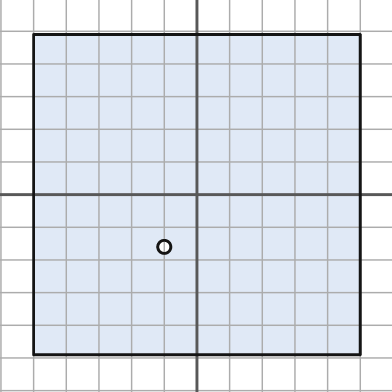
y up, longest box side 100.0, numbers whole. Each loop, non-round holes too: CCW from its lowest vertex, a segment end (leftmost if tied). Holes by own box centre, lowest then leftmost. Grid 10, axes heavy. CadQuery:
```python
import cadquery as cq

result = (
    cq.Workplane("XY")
    .moveTo(-50.0, -49.0)
    .lineTo(50.0, -49.0)
    .lineTo(50.0, 49.0)
    .lineTo(-50.0, 49.0)
    .close()
    .moveTo(-10.0, -16.0)
    .circle(2.0)
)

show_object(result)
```